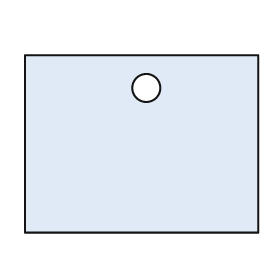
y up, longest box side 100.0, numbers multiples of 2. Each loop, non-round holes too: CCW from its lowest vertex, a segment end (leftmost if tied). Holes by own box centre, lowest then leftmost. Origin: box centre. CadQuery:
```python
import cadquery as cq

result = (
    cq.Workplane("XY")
    .moveTo(-50.0, -38.0)
    .lineTo(50.0, -38.0)
    .lineTo(50.0, 38.0)
    .lineTo(-50.0, 38.0)
    .close()
    .moveTo(2.0, 24.0)
    .circle(6.0)
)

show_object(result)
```